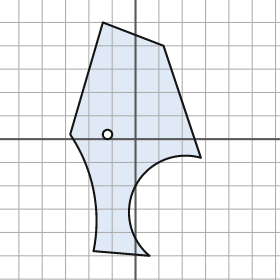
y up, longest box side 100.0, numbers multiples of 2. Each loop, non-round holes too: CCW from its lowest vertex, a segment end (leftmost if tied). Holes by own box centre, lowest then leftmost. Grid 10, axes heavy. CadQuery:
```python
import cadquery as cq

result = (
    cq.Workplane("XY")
    .moveTo(6.0, -50.0)
    .threePointArc((0.0, -20.0), (28.0, -8.0))
    .lineTo(12.0, 40.0)
    .lineTo(-14.0, 50.0)
    .lineTo(-28.0, 2.0)
    .threePointArc((-18.0, -22.0), (-18.0, -48.0))
    .close()
    .moveTo(-12.0, 2.0)
    .circle(2.0)
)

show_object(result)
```